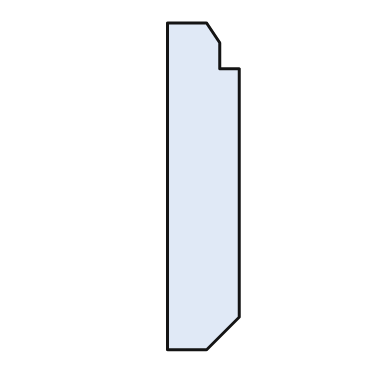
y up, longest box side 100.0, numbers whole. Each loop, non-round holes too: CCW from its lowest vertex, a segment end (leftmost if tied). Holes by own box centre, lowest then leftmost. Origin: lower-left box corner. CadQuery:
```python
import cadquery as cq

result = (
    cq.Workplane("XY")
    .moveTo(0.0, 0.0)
    .lineTo(12.0, 0.0)
    .lineTo(22.0, 10.0)
    .lineTo(22.0, 86.0)
    .lineTo(16.0, 86.0)
    .lineTo(16.0, 94.0)
    .lineTo(12.0, 100.0)
    .lineTo(0.0, 100.0)
    .close()
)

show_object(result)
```